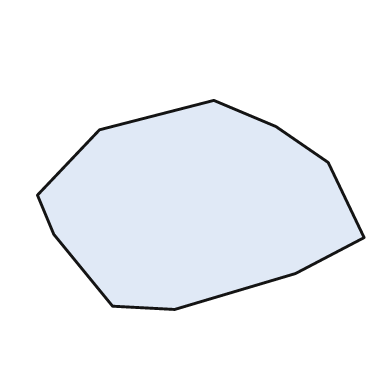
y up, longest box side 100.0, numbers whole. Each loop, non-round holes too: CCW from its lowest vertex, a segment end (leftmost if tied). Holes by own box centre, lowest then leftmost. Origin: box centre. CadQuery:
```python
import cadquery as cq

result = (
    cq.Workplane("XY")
    .moveTo(-8.0, -32.0)
    .lineTo(29.0, -21.0)
    .lineTo(50.0, -10.0)
    .lineTo(39.0, 13.0)
    .lineTo(23.0, 24.0)
    .lineTo(4.0, 32.0)
    .lineTo(-31.0, 23.0)
    .lineTo(-50.0, 3.0)
    .lineTo(-45.0, -9.0)
    .lineTo(-27.0, -31.0)
    .close()
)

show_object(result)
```